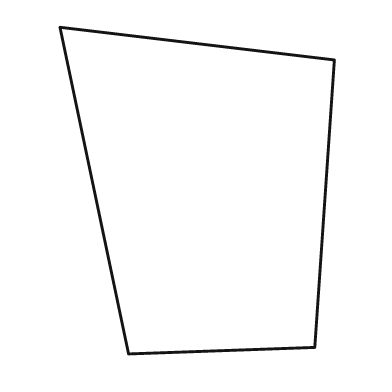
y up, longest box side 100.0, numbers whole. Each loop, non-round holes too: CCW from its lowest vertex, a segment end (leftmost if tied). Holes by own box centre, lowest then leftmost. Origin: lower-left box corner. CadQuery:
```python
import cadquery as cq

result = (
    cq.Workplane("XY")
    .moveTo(21.0, 0.0)
    .lineTo(78.0, 2.0)
    .lineTo(84.0, 90.0)
    .lineTo(0.0, 100.0)
    .close()
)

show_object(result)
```